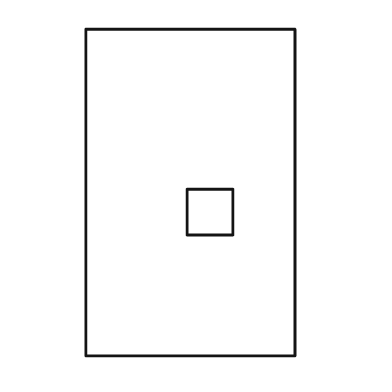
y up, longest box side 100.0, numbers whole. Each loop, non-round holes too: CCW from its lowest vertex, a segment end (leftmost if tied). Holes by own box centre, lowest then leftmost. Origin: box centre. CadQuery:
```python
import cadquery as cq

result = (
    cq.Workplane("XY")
    .moveTo(-32.0, -50.0)
    .lineTo(32.0, -50.0)
    .lineTo(32.0, 50.0)
    .lineTo(-32.0, 50.0)
    .close()
    .moveTo(-1.0, -13.0)
    .lineTo(13.0, -13.0)
    .lineTo(13.0, 1.0)
    .lineTo(-1.0, 1.0)
    .close()
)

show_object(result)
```